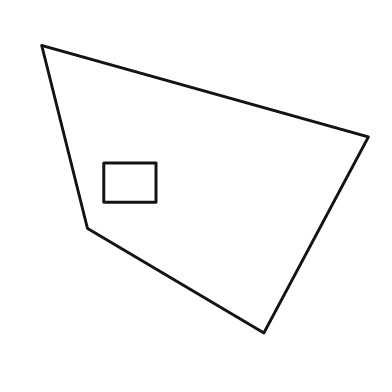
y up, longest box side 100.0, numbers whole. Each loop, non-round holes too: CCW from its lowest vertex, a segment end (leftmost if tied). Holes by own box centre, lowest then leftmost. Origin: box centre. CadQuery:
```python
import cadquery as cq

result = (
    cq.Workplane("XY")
    .moveTo(18.0, -44.0)
    .lineTo(50.0, 16.0)
    .lineTo(-50.0, 44.0)
    .lineTo(-36.0, -12.0)
    .close()
    .moveTo(-31.0, -4.0)
    .lineTo(-15.0, -4.0)
    .lineTo(-15.0, 8.0)
    .lineTo(-31.0, 8.0)
    .close()
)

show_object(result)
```